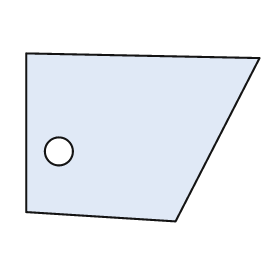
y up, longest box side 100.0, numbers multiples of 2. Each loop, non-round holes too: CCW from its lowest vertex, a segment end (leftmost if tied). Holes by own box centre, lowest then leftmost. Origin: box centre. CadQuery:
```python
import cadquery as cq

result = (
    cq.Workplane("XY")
    .moveTo(14.0, -36.0)
    .lineTo(50.0, 34.0)
    .lineTo(-50.0, 36.0)
    .lineTo(-50.0, -32.0)
    .close()
    .moveTo(-36.0, -6.0)
    .circle(6.0)
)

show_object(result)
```